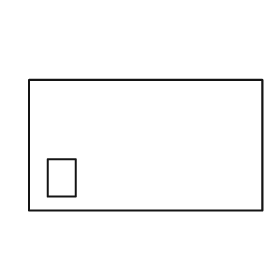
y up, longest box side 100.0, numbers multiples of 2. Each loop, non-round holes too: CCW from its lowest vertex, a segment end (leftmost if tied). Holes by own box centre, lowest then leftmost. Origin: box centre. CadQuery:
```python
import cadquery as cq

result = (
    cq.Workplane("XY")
    .moveTo(-50.0, -28.0)
    .lineTo(50.0, -28.0)
    .lineTo(50.0, 28.0)
    .lineTo(-50.0, 28.0)
    .close()
    .moveTo(-42.0, -22.0)
    .lineTo(-30.0, -22.0)
    .lineTo(-30.0, -6.0)
    .lineTo(-42.0, -6.0)
    .close()
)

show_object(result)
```